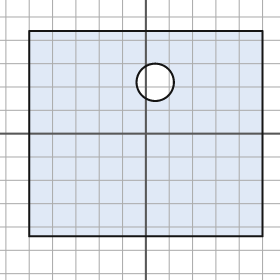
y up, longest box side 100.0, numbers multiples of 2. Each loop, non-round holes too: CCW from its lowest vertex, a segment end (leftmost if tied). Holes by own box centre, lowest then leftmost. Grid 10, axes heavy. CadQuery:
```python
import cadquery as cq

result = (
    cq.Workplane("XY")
    .moveTo(-50.0, -44.0)
    .lineTo(50.0, -44.0)
    .lineTo(50.0, 44.0)
    .lineTo(-50.0, 44.0)
    .close()
    .moveTo(4.0, 22.0)
    .circle(8.0)
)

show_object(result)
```